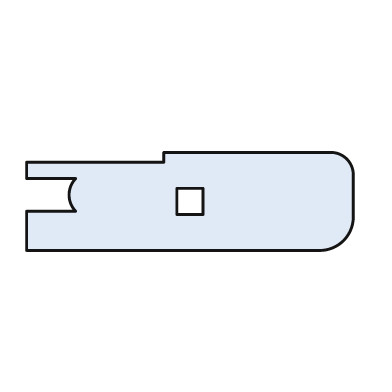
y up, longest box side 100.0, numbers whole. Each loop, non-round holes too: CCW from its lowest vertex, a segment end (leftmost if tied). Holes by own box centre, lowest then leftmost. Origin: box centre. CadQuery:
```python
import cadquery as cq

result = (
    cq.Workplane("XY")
    .moveTo(-50.0, -15.0)
    .lineTo(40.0, -15.0)
    .threePointArc((47.0, -12.0), (50.0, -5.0))
    .lineTo(50.0, 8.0)
    .threePointArc((48.0, 13.0), (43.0, 15.0))
    .lineTo(-8.0, 15.0)
    .lineTo(-8.0, 12.0)
    .lineTo(-50.0, 12.0)
    .lineTo(-50.0, 7.0)
    .lineTo(-35.0, 7.0)
    .threePointArc((-37.0, 2.0), (-35.0, -3.0))
    .lineTo(-50.0, -3.0)
    .close()
    .moveTo(-4.0, -4.0)
    .lineTo(4.0, -4.0)
    .lineTo(4.0, 4.0)
    .lineTo(-4.0, 4.0)
    .close()
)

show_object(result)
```